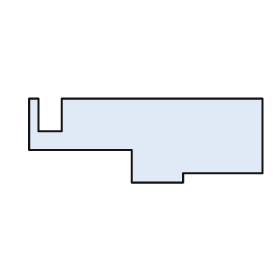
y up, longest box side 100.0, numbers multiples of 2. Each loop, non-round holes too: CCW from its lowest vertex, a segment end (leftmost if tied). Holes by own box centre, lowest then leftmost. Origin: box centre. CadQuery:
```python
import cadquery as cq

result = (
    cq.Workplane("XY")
    .moveTo(-6.0, -18.0)
    .lineTo(16.0, -18.0)
    .lineTo(16.0, -14.0)
    .lineTo(50.0, -14.0)
    .lineTo(50.0, 18.0)
    .lineTo(-36.0, 18.0)
    .lineTo(-36.0, 4.0)
    .lineTo(-46.0, 4.0)
    .lineTo(-46.0, 18.0)
    .lineTo(-50.0, 18.0)
    .lineTo(-50.0, -4.0)
    .lineTo(-6.0, -4.0)
    .close()
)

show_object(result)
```